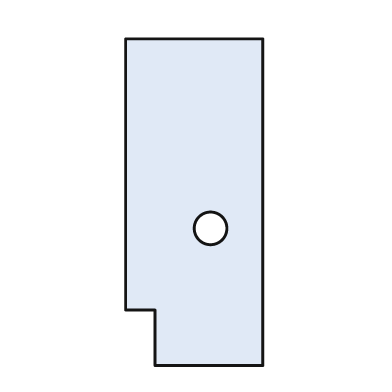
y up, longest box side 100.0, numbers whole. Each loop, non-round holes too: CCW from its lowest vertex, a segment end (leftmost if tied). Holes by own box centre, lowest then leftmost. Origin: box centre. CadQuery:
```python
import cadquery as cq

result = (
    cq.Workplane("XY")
    .moveTo(-12.0, -50.0)
    .lineTo(21.0, -50.0)
    .lineTo(21.0, 50.0)
    .lineTo(-21.0, 50.0)
    .lineTo(-21.0, -33.0)
    .lineTo(-12.0, -33.0)
    .close()
    .moveTo(5.0, -8.0)
    .circle(5.0)
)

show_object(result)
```